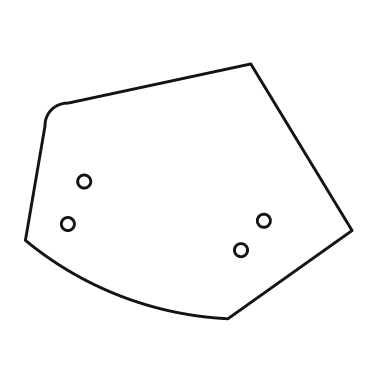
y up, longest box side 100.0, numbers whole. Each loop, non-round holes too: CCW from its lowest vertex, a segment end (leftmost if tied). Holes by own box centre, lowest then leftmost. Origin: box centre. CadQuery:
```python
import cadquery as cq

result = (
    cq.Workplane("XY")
    .moveTo(12.0, -39.0)
    .lineTo(50.0, -12.0)
    .lineTo(19.0, 39.0)
    .lineTo(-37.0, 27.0)
    .threePointArc((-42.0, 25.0), (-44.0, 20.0))
    .lineTo(-50.0, -15.0)
    .threePointArc((-21.0, -32.0), (12.0, -39.0))
    .close()
    .moveTo(16.0, -18.0)
    .circle(2.0)
    .moveTo(-37.0, -10.0)
    .circle(2.0)
    .moveTo(23.0, -9.0)
    .circle(2.0)
    .moveTo(-32.0, 3.0)
    .circle(2.0)
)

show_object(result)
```